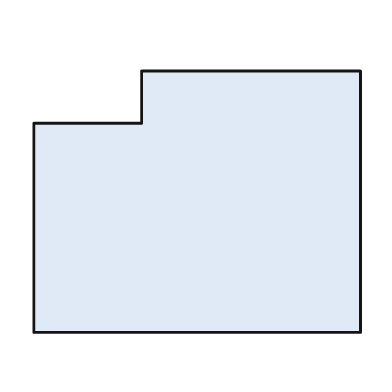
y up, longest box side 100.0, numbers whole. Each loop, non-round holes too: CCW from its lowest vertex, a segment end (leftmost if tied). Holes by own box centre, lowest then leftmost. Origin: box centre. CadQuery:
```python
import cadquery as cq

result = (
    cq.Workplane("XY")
    .moveTo(-50.0, -40.0)
    .lineTo(50.0, -40.0)
    .lineTo(50.0, 40.0)
    .lineTo(-17.0, 40.0)
    .lineTo(-17.0, 24.0)
    .lineTo(-50.0, 24.0)
    .close()
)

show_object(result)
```